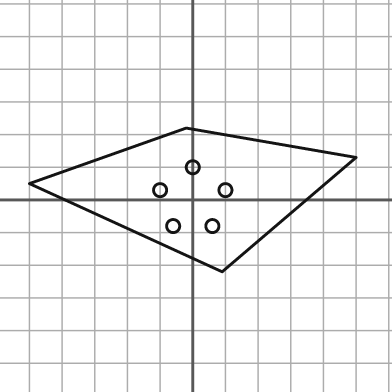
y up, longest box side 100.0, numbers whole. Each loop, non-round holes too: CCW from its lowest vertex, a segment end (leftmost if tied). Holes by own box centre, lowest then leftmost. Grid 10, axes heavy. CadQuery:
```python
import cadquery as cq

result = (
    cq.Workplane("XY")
    .moveTo(9.0, -22.0)
    .lineTo(50.0, 13.0)
    .lineTo(-2.0, 22.0)
    .lineTo(-50.0, 5.0)
    .close()
    .moveTo(-6.0, -8.0)
    .circle(2.0)
    .moveTo(6.0, -8.0)
    .circle(2.0)
    .moveTo(-10.0, 3.0)
    .circle(2.0)
    .moveTo(10.0, 3.0)
    .circle(2.0)
    .moveTo(0.0, 10.0)
    .circle(2.0)
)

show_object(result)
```